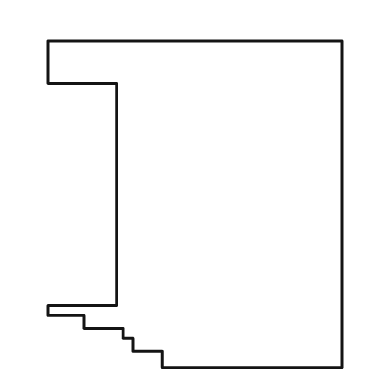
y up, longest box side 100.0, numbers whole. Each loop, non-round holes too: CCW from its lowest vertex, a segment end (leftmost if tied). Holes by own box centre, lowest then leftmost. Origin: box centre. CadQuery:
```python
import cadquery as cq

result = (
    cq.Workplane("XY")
    .moveTo(-10.0, -50.0)
    .lineTo(45.0, -50.0)
    .lineTo(45.0, 50.0)
    .lineTo(-45.0, 50.0)
    .lineTo(-45.0, 37.0)
    .lineTo(-24.0, 37.0)
    .lineTo(-24.0, -31.0)
    .lineTo(-45.0, -31.0)
    .lineTo(-45.0, -34.0)
    .lineTo(-34.0, -34.0)
    .lineTo(-34.0, -38.0)
    .lineTo(-22.0, -38.0)
    .lineTo(-22.0, -41.0)
    .lineTo(-19.0, -41.0)
    .lineTo(-19.0, -45.0)
    .lineTo(-10.0, -45.0)
    .close()
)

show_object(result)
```